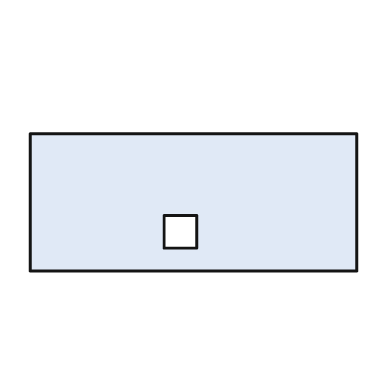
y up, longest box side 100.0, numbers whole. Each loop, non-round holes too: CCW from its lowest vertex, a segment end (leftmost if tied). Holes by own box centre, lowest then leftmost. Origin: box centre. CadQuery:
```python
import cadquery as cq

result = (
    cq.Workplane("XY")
    .moveTo(-50.0, -21.0)
    .lineTo(50.0, -21.0)
    .lineTo(50.0, 21.0)
    .lineTo(-50.0, 21.0)
    .close()
    .moveTo(-9.0, -14.0)
    .lineTo(1.0, -14.0)
    .lineTo(1.0, -4.0)
    .lineTo(-9.0, -4.0)
    .close()
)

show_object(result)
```